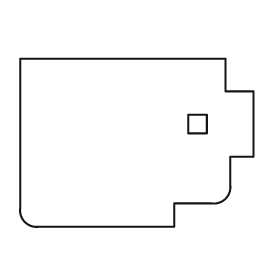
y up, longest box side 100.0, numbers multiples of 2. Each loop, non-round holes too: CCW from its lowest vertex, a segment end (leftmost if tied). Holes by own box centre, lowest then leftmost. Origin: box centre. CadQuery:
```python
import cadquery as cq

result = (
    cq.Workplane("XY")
    .moveTo(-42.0, -36.0)
    .lineTo(16.0, -36.0)
    .lineTo(16.0, -26.0)
    .lineTo(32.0, -26.0)
    .threePointArc((38.0, -24.0), (40.0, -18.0))
    .lineTo(40.0, -6.0)
    .lineTo(50.0, -6.0)
    .lineTo(50.0, 22.0)
    .lineTo(38.0, 22.0)
    .lineTo(38.0, 36.0)
    .lineTo(-50.0, 36.0)
    .lineTo(-50.0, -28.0)
    .threePointArc((-48.0, -34.0), (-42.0, -36.0))
    .close()
    .moveTo(22.0, 4.0)
    .lineTo(30.0, 4.0)
    .lineTo(30.0, 12.0)
    .lineTo(22.0, 12.0)
    .close()
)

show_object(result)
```